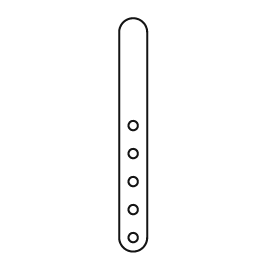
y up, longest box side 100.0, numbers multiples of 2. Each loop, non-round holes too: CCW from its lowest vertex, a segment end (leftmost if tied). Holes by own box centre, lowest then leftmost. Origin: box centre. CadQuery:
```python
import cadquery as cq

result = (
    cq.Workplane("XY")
    .moveTo(-6.0, -44.0)
    .threePointArc((0.0, -50.0), (6.0, -44.0))
    .lineTo(6.0, 44.0)
    .threePointArc((0.0, 50.0), (-6.0, 44.0))
    .close()
    .moveTo(0.0, -44.0)
    .circle(2.0)
    .moveTo(0.0, -32.0)
    .circle(2.0)
    .moveTo(0.0, -20.0)
    .circle(2.0)
    .moveTo(0.0, -8.0)
    .circle(2.0)
    .moveTo(0.0, 4.0)
    .circle(2.0)
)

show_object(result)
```